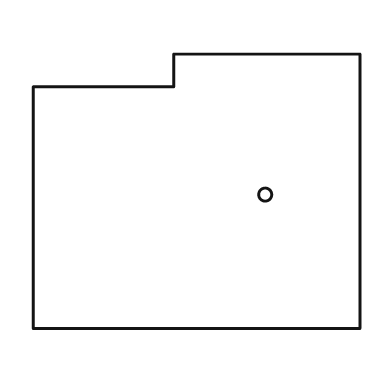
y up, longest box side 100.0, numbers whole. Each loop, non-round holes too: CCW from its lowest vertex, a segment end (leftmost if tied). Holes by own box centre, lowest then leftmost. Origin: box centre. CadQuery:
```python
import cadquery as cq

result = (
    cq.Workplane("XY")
    .moveTo(-50.0, -42.0)
    .lineTo(50.0, -42.0)
    .lineTo(50.0, 42.0)
    .lineTo(-7.0, 42.0)
    .lineTo(-7.0, 32.0)
    .lineTo(-50.0, 32.0)
    .close()
    .moveTo(21.0, -1.0)
    .circle(2.0)
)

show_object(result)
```